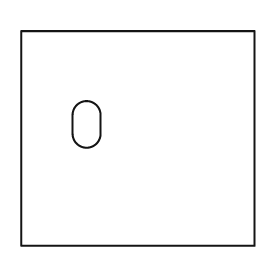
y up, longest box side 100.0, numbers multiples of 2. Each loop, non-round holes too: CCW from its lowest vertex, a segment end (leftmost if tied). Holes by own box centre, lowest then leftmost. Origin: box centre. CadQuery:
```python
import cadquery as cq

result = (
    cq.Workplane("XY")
    .moveTo(-50.0, -46.0)
    .lineTo(50.0, -46.0)
    .lineTo(50.0, 46.0)
    .lineTo(-50.0, 46.0)
    .close()
    .moveTo(-28.0, 2.0)
    .threePointArc((-22.0, -4.0), (-16.0, 2.0))
    .lineTo(-16.0, 10.0)
    .threePointArc((-22.0, 16.0), (-28.0, 10.0))
    .close()
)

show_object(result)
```